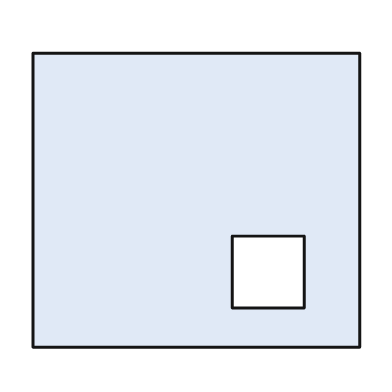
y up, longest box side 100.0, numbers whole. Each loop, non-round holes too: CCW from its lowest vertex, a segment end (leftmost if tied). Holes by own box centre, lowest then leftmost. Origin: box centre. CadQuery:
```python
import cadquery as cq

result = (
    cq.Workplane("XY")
    .moveTo(-50.0, -45.0)
    .lineTo(50.0, -45.0)
    .lineTo(50.0, 45.0)
    .lineTo(-50.0, 45.0)
    .close()
    .moveTo(11.0, -33.0)
    .lineTo(33.0, -33.0)
    .lineTo(33.0, -11.0)
    .lineTo(11.0, -11.0)
    .close()
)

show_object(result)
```